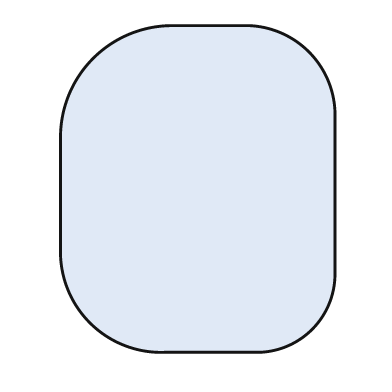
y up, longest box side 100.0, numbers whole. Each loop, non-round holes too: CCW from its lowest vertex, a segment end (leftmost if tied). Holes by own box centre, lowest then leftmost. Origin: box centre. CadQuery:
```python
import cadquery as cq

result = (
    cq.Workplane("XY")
    .moveTo(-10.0, -50.0)
    .lineTo(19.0, -50.0)
    .threePointArc((35.0, -43.0), (42.0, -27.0))
    .lineTo(42.0, 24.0)
    .threePointArc((34.0, 42.0), (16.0, 50.0))
    .lineTo(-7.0, 50.0)
    .threePointArc((-32.0, 40.0), (-42.0, 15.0))
    .lineTo(-42.0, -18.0)
    .threePointArc((-33.0, -41.0), (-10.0, -50.0))
    .close()
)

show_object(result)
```